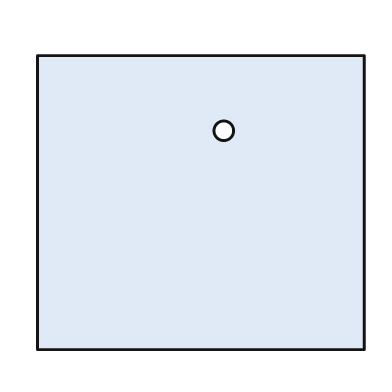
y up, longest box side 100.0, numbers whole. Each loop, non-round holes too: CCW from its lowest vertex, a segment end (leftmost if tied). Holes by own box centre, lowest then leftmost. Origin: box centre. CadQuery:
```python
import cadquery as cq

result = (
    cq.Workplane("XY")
    .moveTo(-50.0, -45.0)
    .lineTo(50.0, -45.0)
    .lineTo(50.0, 45.0)
    .lineTo(-50.0, 45.0)
    .close()
    .moveTo(7.0, 22.0)
    .circle(3.0)
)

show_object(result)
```